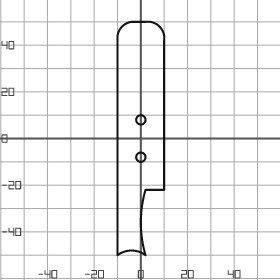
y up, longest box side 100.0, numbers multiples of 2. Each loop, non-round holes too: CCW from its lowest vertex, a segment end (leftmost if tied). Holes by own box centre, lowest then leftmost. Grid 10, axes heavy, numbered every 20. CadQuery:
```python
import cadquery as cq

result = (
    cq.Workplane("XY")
    .moveTo(-10.0, -50.0)
    .threePointArc((-4.0, -48.0), (2.0, -50.0))
    .threePointArc((0.0, -36.0), (2.0, -22.0))
    .lineTo(10.0, -22.0)
    .lineTo(10.0, 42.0)
    .threePointArc((8.0, 48.0), (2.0, 50.0))
    .lineTo(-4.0, 50.0)
    .threePointArc((-8.0, 48.0), (-10.0, 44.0))
    .close()
    .moveTo(0.0, -8.0)
    .circle(2.0)
    .moveTo(0.0, 8.0)
    .circle(2.0)
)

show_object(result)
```